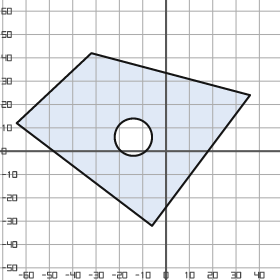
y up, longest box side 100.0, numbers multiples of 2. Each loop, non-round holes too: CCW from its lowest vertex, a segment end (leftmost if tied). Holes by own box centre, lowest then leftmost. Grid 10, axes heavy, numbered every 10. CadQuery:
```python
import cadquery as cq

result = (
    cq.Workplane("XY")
    .moveTo(-6.0, -32.0)
    .lineTo(36.0, 24.0)
    .lineTo(-32.0, 42.0)
    .lineTo(-64.0, 12.0)
    .close()
    .moveTo(-14.0, 6.0)
    .circle(8.0)
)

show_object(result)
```